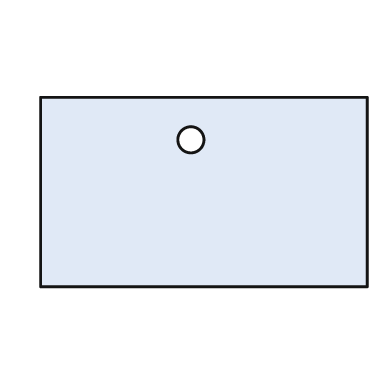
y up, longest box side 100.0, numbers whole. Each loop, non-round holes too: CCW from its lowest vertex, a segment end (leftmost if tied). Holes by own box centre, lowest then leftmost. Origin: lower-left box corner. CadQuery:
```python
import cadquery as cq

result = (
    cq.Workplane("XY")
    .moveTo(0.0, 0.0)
    .lineTo(100.0, 0.0)
    .lineTo(100.0, 58.0)
    .lineTo(0.0, 58.0)
    .close()
    .moveTo(46.0, 45.0)
    .circle(4.0)
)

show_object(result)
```